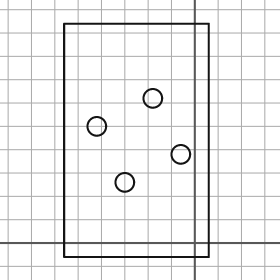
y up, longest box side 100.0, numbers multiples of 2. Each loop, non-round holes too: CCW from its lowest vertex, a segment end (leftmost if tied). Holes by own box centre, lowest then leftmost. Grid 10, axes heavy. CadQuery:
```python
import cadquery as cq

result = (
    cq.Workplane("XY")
    .moveTo(-56.0, -6.0)
    .lineTo(6.0, -6.0)
    .lineTo(6.0, 94.0)
    .lineTo(-56.0, 94.0)
    .close()
    .moveTo(-30.0, 26.0)
    .circle(4.0)
    .moveTo(-6.0, 38.0)
    .circle(4.0)
    .moveTo(-42.0, 50.0)
    .circle(4.0)
    .moveTo(-18.0, 62.0)
    .circle(4.0)
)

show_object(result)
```